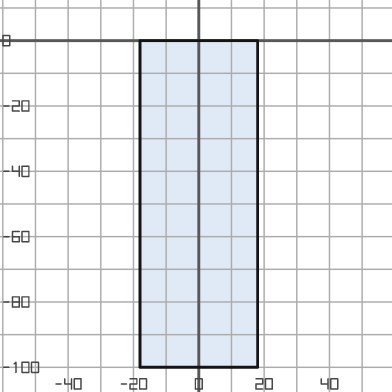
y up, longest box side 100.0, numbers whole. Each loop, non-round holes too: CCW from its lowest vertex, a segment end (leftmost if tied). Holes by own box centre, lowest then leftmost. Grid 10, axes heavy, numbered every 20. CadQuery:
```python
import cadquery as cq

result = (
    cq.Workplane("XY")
    .moveTo(-18.0, -100.0)
    .lineTo(18.0, -100.0)
    .lineTo(18.0, 0.0)
    .lineTo(-18.0, 0.0)
    .close()
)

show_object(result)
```